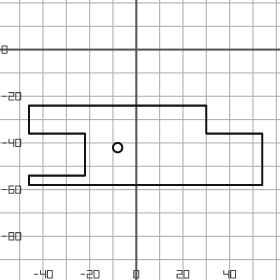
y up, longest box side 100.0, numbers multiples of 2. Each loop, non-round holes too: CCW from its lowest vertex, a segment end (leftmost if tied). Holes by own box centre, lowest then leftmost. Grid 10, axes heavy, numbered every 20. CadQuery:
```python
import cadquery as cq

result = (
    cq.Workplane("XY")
    .moveTo(-46.0, -58.0)
    .lineTo(54.0, -58.0)
    .lineTo(54.0, -36.0)
    .lineTo(30.0, -36.0)
    .lineTo(30.0, -24.0)
    .lineTo(-46.0, -24.0)
    .lineTo(-46.0, -36.0)
    .lineTo(-22.0, -36.0)
    .lineTo(-22.0, -54.0)
    .lineTo(-46.0, -54.0)
    .close()
    .moveTo(-8.0, -42.0)
    .circle(2.0)
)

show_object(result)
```